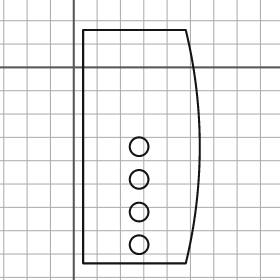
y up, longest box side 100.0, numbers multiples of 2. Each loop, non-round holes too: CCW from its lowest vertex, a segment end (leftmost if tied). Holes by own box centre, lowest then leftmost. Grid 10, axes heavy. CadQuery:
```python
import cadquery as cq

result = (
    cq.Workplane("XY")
    .moveTo(4.0, -84.0)
    .lineTo(48.0, -84.0)
    .threePointArc((54.0, -34.0), (48.0, 16.0))
    .lineTo(4.0, 16.0)
    .close()
    .moveTo(28.0, -76.0)
    .circle(4.0)
    .moveTo(28.0, -62.0)
    .circle(4.0)
    .moveTo(28.0, -48.0)
    .circle(4.0)
    .moveTo(28.0, -34.0)
    .circle(4.0)
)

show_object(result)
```